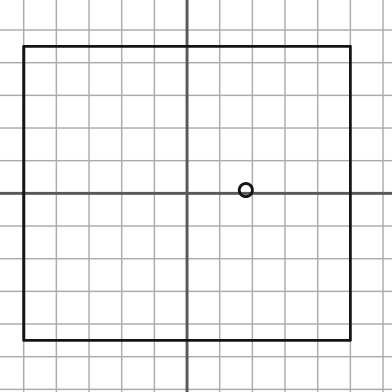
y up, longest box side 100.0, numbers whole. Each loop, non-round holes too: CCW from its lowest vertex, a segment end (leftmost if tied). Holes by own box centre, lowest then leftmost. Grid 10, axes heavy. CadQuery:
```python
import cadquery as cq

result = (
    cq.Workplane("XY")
    .moveTo(-50.0, -45.0)
    .lineTo(50.0, -45.0)
    .lineTo(50.0, 45.0)
    .lineTo(-50.0, 45.0)
    .close()
    .moveTo(18.0, 1.0)
    .circle(2.0)
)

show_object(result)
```